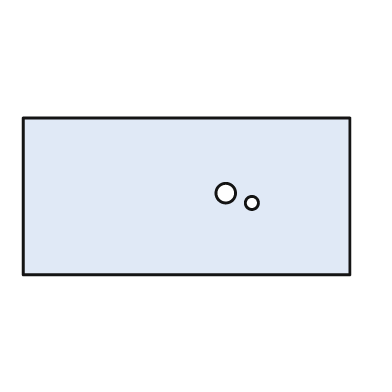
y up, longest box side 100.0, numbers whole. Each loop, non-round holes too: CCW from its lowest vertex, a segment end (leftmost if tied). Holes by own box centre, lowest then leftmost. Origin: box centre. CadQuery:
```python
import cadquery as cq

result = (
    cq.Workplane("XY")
    .moveTo(-50.0, -24.0)
    .lineTo(50.0, -24.0)
    .lineTo(50.0, 24.0)
    .lineTo(-50.0, 24.0)
    .close()
    .moveTo(20.0, -2.0)
    .circle(2.0)
    .moveTo(12.0, 1.0)
    .circle(3.0)
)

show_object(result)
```